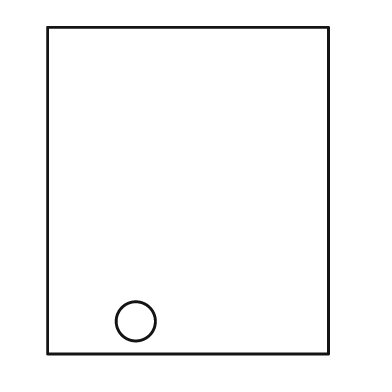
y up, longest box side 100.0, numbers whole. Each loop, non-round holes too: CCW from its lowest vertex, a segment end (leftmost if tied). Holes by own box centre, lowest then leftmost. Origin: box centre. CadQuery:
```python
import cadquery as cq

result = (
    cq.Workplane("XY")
    .moveTo(-43.0, -50.0)
    .lineTo(43.0, -50.0)
    .lineTo(43.0, 50.0)
    .lineTo(-43.0, 50.0)
    .close()
    .moveTo(-16.0, -40.0)
    .circle(6.0)
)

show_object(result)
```